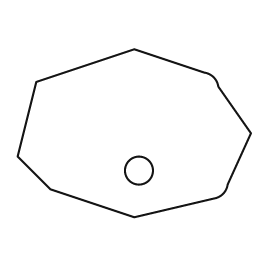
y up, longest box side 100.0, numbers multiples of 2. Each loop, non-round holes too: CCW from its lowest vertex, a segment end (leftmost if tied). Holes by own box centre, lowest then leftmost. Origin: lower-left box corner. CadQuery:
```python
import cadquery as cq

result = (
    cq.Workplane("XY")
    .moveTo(50.0, 0.0)
    .lineTo(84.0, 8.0)
    .threePointArc((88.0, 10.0), (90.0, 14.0))
    .lineTo(100.0, 36.0)
    .lineTo(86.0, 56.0)
    .threePointArc((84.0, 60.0), (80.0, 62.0))
    .lineTo(50.0, 72.0)
    .lineTo(8.0, 58.0)
    .lineTo(0.0, 26.0)
    .lineTo(14.0, 12.0)
    .close()
    .moveTo(52.0, 20.0)
    .circle(6.0)
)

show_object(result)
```